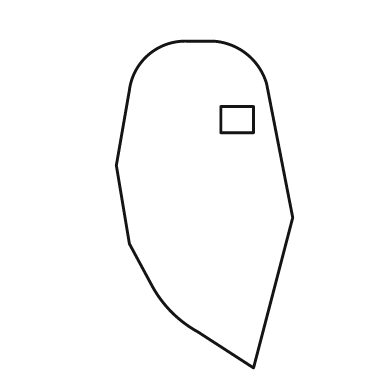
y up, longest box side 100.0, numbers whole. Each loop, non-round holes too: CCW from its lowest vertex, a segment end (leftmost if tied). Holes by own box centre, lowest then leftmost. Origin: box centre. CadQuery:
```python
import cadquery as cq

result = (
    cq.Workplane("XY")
    .moveTo(15.0, -50.0)
    .lineTo(27.0, -4.0)
    .lineTo(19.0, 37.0)
    .threePointArc((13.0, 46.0), (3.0, 50.0))
    .lineTo(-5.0, 50.0)
    .threePointArc((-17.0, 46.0), (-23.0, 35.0))
    .lineTo(-27.0, 12.0)
    .lineTo(-23.0, -12.0)
    .lineTo(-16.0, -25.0)
    .threePointArc((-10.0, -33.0), (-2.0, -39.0))
    .close()
    .moveTo(5.0, 22.0)
    .lineTo(15.0, 22.0)
    .lineTo(15.0, 30.0)
    .lineTo(5.0, 30.0)
    .close()
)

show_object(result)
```